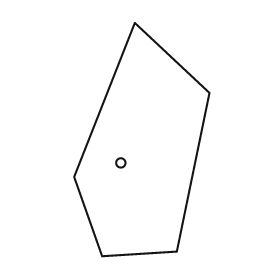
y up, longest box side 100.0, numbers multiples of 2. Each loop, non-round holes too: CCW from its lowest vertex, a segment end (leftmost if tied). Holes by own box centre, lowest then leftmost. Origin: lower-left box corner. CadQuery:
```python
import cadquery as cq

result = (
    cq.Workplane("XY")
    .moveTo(12.0, 0.0)
    .lineTo(44.0, 2.0)
    .lineTo(58.0, 70.0)
    .lineTo(26.0, 100.0)
    .lineTo(0.0, 34.0)
    .close()
    .moveTo(20.0, 40.0)
    .circle(2.0)
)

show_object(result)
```